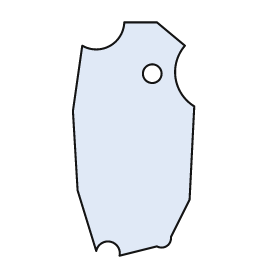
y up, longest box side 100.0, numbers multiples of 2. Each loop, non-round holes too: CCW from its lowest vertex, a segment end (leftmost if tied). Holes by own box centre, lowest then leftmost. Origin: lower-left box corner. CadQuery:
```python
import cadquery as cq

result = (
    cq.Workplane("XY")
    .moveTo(20.0, 0.0)
    .lineTo(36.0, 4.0)
    .threePointArc((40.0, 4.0), (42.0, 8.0))
    .lineTo(50.0, 24.0)
    .lineTo(52.0, 64.0)
    .threePointArc((44.0, 76.0), (48.0, 90.0))
    .lineTo(36.0, 100.0)
    .lineTo(22.0, 100.0)
    .threePointArc((16.0, 90.0), (4.0, 90.0))
    .lineTo(0.0, 62.0)
    .lineTo(2.0, 28.0)
    .lineTo(10.0, 2.0)
    .threePointArc((16.0, 6.0), (20.0, 0.0))
    .close()
    .moveTo(34.0, 78.0)
    .circle(4.0)
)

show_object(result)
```